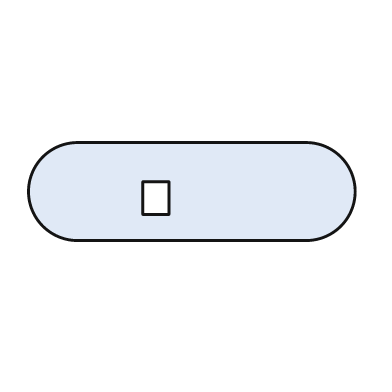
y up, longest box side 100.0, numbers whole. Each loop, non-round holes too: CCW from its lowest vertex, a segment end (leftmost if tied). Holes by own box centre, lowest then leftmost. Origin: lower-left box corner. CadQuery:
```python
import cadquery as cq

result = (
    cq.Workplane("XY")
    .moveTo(15.0, 0.0)
    .lineTo(85.0, 0.0)
    .threePointArc((100.0, 15.0), (85.0, 30.0))
    .lineTo(15.0, 30.0)
    .threePointArc((0.0, 15.0), (15.0, 0.0))
    .close()
    .moveTo(35.0, 8.0)
    .lineTo(43.0, 8.0)
    .lineTo(43.0, 18.0)
    .lineTo(35.0, 18.0)
    .close()
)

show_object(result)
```